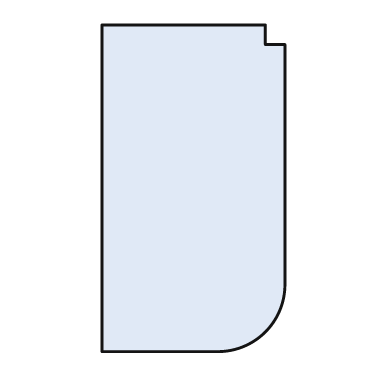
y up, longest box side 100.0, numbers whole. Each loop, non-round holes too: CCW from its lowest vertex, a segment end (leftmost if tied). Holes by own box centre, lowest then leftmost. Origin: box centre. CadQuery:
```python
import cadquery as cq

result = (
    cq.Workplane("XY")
    .moveTo(-28.0, -50.0)
    .lineTo(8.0, -50.0)
    .threePointArc((22.0, -44.0), (28.0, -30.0))
    .lineTo(28.0, 44.0)
    .lineTo(22.0, 44.0)
    .lineTo(22.0, 50.0)
    .lineTo(-28.0, 50.0)
    .close()
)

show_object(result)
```